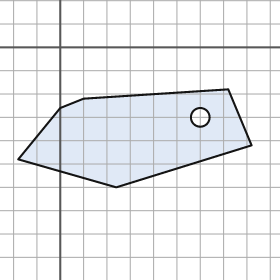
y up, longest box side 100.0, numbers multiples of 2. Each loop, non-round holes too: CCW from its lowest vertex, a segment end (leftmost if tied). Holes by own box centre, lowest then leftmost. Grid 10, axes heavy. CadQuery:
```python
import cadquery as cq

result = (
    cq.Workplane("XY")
    .moveTo(24.0, -60.0)
    .lineTo(82.0, -42.0)
    .lineTo(72.0, -18.0)
    .lineTo(10.0, -22.0)
    .lineTo(0.0, -26.0)
    .lineTo(-18.0, -48.0)
    .close()
    .moveTo(60.0, -30.0)
    .circle(4.0)
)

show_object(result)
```